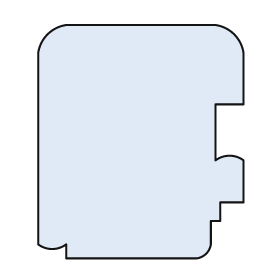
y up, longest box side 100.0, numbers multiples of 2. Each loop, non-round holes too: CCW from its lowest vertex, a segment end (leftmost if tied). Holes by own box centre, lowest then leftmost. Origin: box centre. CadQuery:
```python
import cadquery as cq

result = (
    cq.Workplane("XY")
    .moveTo(-32.0, -50.0)
    .lineTo(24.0, -50.0)
    .threePointArc((28.0, -48.0), (30.0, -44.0))
    .lineTo(30.0, -34.0)
    .lineTo(34.0, -34.0)
    .lineTo(34.0, -26.0)
    .lineTo(44.0, -26.0)
    .lineTo(44.0, -8.0)
    .threePointArc((38.0, -6.0), (32.0, -8.0))
    .lineTo(32.0, 16.0)
    .lineTo(44.0, 16.0)
    .lineTo(44.0, 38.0)
    .threePointArc((40.0, 46.0), (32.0, 50.0))
    .lineTo(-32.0, 50.0)
    .threePointArc((-40.0, 46.0), (-44.0, 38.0))
    .lineTo(-44.0, -44.0)
    .threePointArc((-38.0, -46.0), (-32.0, -44.0))
    .close()
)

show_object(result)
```